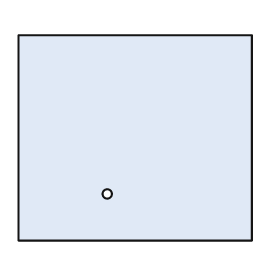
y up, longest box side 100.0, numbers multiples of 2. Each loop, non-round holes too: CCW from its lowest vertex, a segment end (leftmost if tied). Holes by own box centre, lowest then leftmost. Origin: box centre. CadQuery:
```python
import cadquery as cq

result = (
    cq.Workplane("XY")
    .moveTo(-50.0, -44.0)
    .lineTo(50.0, -44.0)
    .lineTo(50.0, 44.0)
    .lineTo(-50.0, 44.0)
    .close()
    .moveTo(-12.0, -24.0)
    .circle(2.0)
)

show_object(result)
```